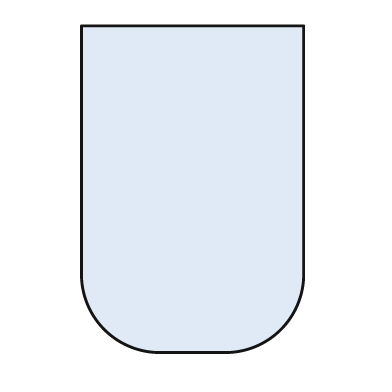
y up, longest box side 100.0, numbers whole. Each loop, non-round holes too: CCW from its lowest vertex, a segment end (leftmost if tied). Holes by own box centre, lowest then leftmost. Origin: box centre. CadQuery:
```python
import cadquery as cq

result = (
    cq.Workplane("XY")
    .moveTo(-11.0, -50.0)
    .lineTo(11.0, -50.0)
    .threePointArc((27.0, -43.0), (34.0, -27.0))
    .lineTo(34.0, 50.0)
    .lineTo(-34.0, 50.0)
    .lineTo(-34.0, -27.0)
    .threePointArc((-27.0, -43.0), (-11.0, -50.0))
    .close()
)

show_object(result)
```